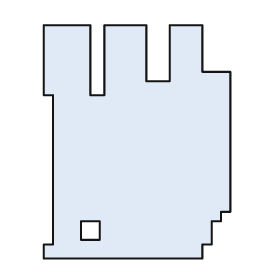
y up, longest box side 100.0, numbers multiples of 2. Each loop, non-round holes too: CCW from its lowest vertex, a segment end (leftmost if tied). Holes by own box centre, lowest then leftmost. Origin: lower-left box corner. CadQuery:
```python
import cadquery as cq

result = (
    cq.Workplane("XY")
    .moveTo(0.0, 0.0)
    .lineTo(68.0, 0.0)
    .lineTo(68.0, 6.0)
    .lineTo(72.0, 6.0)
    .lineTo(72.0, 16.0)
    .lineTo(76.0, 16.0)
    .lineTo(76.0, 20.0)
    .lineTo(80.0, 20.0)
    .lineTo(80.0, 80.0)
    .lineTo(68.0, 80.0)
    .lineTo(68.0, 100.0)
    .lineTo(54.0, 100.0)
    .lineTo(54.0, 76.0)
    .lineTo(44.0, 76.0)
    .lineTo(44.0, 100.0)
    .lineTo(26.0, 100.0)
    .lineTo(26.0, 70.0)
    .lineTo(20.0, 70.0)
    .lineTo(20.0, 100.0)
    .lineTo(0.0, 100.0)
    .lineTo(0.0, 70.0)
    .lineTo(4.0, 70.0)
    .lineTo(4.0, 6.0)
    .lineTo(0.0, 6.0)
    .close()
    .moveTo(16.0, 8.0)
    .lineTo(24.0, 8.0)
    .lineTo(24.0, 16.0)
    .lineTo(16.0, 16.0)
    .close()
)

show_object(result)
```